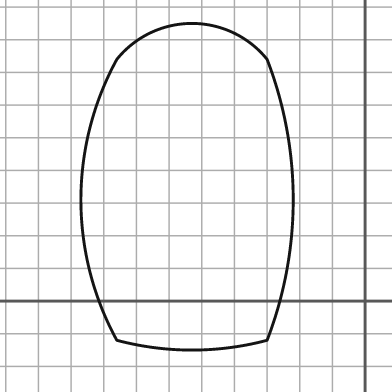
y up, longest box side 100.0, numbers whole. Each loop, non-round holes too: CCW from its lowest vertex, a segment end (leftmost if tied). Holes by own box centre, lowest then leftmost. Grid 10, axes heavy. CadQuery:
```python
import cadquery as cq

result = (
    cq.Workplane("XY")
    .moveTo(-76.0, -12.0)
    .threePointArc((-53.0, -15.0), (-30.0, -12.0))
    .threePointArc((-22.0, 31.0), (-30.0, 74.0))
    .threePointArc((-53.0, 85.0), (-76.0, 74.0))
    .threePointArc((-87.0, 31.0), (-76.0, -12.0))
    .close()
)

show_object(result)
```